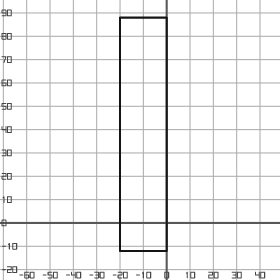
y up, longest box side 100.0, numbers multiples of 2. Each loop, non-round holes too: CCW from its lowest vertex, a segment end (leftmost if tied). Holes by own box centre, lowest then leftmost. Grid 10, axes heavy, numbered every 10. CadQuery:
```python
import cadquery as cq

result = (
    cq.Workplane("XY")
    .moveTo(-20.0, -12.0)
    .lineTo(0.0, -12.0)
    .lineTo(0.0, 88.0)
    .lineTo(-20.0, 88.0)
    .close()
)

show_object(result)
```